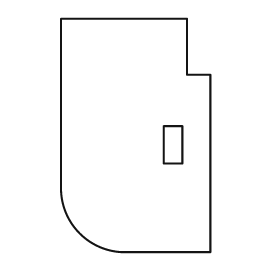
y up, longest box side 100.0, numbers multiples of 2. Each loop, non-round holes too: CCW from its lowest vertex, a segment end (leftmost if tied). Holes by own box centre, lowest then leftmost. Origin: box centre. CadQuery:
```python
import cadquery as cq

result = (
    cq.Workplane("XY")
    .moveTo(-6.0, -50.0)
    .lineTo(32.0, -50.0)
    .lineTo(32.0, 26.0)
    .lineTo(22.0, 26.0)
    .lineTo(22.0, 50.0)
    .lineTo(-32.0, 50.0)
    .lineTo(-32.0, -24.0)
    .threePointArc((-24.0, -42.0), (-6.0, -50.0))
    .close()
    .moveTo(12.0, -12.0)
    .lineTo(20.0, -12.0)
    .lineTo(20.0, 4.0)
    .lineTo(12.0, 4.0)
    .close()
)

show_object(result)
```